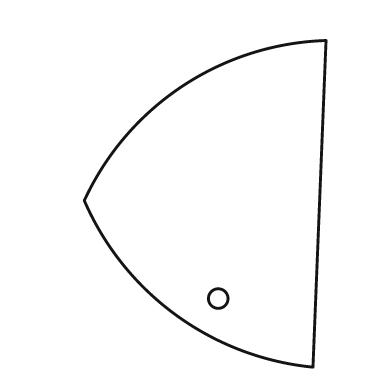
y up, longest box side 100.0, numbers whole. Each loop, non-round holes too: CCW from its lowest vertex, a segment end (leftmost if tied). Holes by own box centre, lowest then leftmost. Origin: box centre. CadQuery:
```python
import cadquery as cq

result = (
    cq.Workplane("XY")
    .moveTo(33.0, -50.0)
    .lineTo(37.0, 50.0)
    .threePointArc((-7.0, 36.0), (-37.0, 1.0))
    .threePointArc((-9.0, -34.0), (33.0, -50.0))
    .close()
    .moveTo(4.0, -29.0)
    .circle(3.0)
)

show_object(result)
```